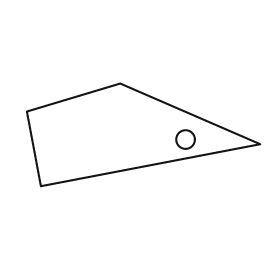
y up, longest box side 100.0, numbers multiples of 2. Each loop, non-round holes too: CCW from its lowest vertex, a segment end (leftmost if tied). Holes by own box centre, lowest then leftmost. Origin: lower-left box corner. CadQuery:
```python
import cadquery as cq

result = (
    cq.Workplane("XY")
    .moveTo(6.0, 0.0)
    .lineTo(100.0, 18.0)
    .lineTo(40.0, 44.0)
    .lineTo(0.0, 32.0)
    .close()
    .moveTo(68.0, 20.0)
    .circle(4.0)
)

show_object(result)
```